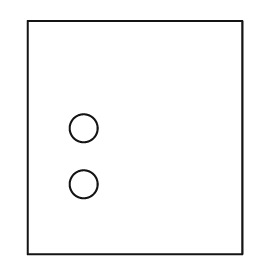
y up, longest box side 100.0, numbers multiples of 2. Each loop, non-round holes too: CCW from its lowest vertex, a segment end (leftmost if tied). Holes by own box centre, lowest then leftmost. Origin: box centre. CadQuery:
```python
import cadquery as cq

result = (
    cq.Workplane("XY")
    .moveTo(-46.0, -50.0)
    .lineTo(46.0, -50.0)
    .lineTo(46.0, 50.0)
    .lineTo(-46.0, 50.0)
    .close()
    .moveTo(-22.0, -20.0)
    .circle(6.0)
    .moveTo(-22.0, 4.0)
    .circle(6.0)
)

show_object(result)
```